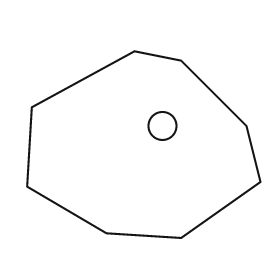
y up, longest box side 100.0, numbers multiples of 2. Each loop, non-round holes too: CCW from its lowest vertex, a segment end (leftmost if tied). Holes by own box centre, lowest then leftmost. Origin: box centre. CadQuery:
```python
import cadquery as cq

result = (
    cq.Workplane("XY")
    .moveTo(16.0, -40.0)
    .lineTo(50.0, -16.0)
    .lineTo(44.0, 8.0)
    .lineTo(16.0, 36.0)
    .lineTo(-4.0, 40.0)
    .lineTo(-48.0, 16.0)
    .lineTo(-50.0, -18.0)
    .lineTo(-16.0, -38.0)
    .close()
    .moveTo(8.0, 8.0)
    .circle(6.0)
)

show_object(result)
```